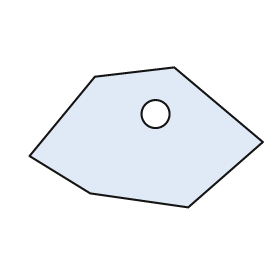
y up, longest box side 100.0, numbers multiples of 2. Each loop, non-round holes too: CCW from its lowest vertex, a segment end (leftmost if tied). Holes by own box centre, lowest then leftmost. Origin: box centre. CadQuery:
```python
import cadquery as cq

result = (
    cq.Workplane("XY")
    .moveTo(18.0, -30.0)
    .lineTo(50.0, -2.0)
    .lineTo(12.0, 30.0)
    .lineTo(-22.0, 26.0)
    .lineTo(-50.0, -8.0)
    .lineTo(-24.0, -24.0)
    .close()
    .moveTo(4.0, 10.0)
    .circle(6.0)
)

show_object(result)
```